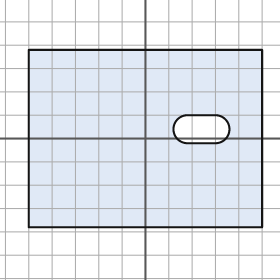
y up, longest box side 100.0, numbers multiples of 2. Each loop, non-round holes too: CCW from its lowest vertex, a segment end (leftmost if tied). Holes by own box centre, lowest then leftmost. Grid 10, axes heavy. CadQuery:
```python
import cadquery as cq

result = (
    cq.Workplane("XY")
    .moveTo(-50.0, -38.0)
    .lineTo(50.0, -38.0)
    .lineTo(50.0, 38.0)
    .lineTo(-50.0, 38.0)
    .close()
    .moveTo(18.0, -2.0)
    .lineTo(30.0, -2.0)
    .threePointArc((36.0, 4.0), (30.0, 10.0))
    .lineTo(18.0, 10.0)
    .threePointArc((12.0, 4.0), (18.0, -2.0))
    .close()
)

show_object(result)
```